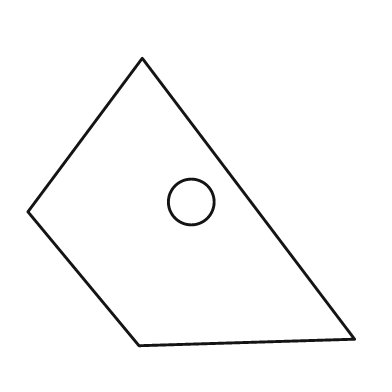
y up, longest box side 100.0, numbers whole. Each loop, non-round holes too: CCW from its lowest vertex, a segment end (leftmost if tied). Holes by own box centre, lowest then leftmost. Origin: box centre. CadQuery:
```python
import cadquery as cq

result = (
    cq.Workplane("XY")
    .moveTo(-16.0, -44.0)
    .lineTo(50.0, -42.0)
    .lineTo(-15.0, 44.0)
    .lineTo(-50.0, -3.0)
    .close()
    .moveTo(0.0, 0.0)
    .circle(7.0)
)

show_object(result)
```